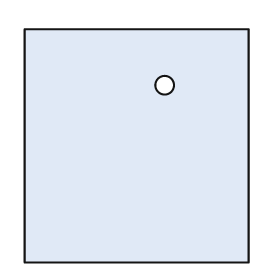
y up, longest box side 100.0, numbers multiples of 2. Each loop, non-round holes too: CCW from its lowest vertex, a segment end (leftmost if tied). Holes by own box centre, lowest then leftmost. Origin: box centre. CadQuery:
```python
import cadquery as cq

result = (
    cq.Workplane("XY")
    .moveTo(-48.0, -50.0)
    .lineTo(48.0, -50.0)
    .lineTo(48.0, 50.0)
    .lineTo(-48.0, 50.0)
    .close()
    .moveTo(12.0, 26.0)
    .circle(4.0)
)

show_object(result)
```